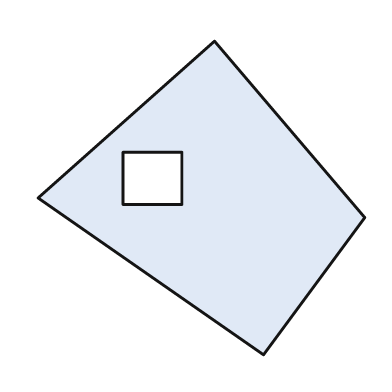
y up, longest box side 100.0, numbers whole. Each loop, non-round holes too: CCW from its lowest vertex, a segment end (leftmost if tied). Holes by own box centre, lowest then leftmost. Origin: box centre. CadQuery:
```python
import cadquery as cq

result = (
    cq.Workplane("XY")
    .moveTo(19.0, -48.0)
    .lineTo(50.0, -6.0)
    .lineTo(4.0, 48.0)
    .lineTo(-50.0, 0.0)
    .close()
    .moveTo(-24.0, -2.0)
    .lineTo(-6.0, -2.0)
    .lineTo(-6.0, 14.0)
    .lineTo(-24.0, 14.0)
    .close()
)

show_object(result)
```